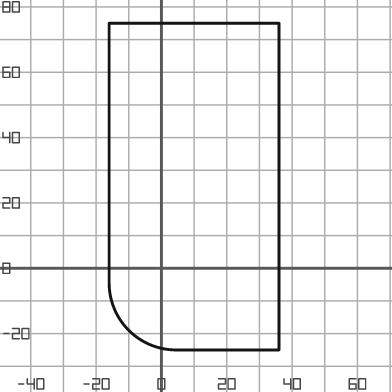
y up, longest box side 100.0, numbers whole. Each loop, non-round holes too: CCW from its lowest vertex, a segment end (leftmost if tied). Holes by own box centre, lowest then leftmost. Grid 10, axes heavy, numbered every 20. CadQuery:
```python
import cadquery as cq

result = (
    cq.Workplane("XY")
    .moveTo(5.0, -25.0)
    .lineTo(36.0, -25.0)
    .lineTo(36.0, 75.0)
    .lineTo(-16.0, 75.0)
    .lineTo(-16.0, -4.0)
    .threePointArc((-10.0, -19.0), (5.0, -25.0))
    .close()
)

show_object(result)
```